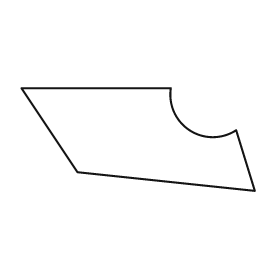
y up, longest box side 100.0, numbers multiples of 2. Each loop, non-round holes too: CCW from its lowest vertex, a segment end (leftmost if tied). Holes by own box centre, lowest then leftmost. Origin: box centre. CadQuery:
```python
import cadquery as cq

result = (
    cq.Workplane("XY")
    .moveTo(50.0, -22.0)
    .lineTo(42.0, 4.0)
    .threePointArc((22.0, 4.0), (14.0, 22.0))
    .lineTo(-50.0, 22.0)
    .lineTo(-26.0, -14.0)
    .close()
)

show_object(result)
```